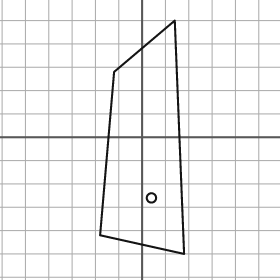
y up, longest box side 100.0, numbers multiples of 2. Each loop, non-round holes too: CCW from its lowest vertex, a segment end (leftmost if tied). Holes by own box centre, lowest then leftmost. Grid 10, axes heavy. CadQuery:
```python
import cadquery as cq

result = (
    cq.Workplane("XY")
    .moveTo(18.0, -50.0)
    .lineTo(14.0, 50.0)
    .lineTo(-12.0, 28.0)
    .lineTo(-18.0, -42.0)
    .close()
    .moveTo(4.0, -26.0)
    .circle(2.0)
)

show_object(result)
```